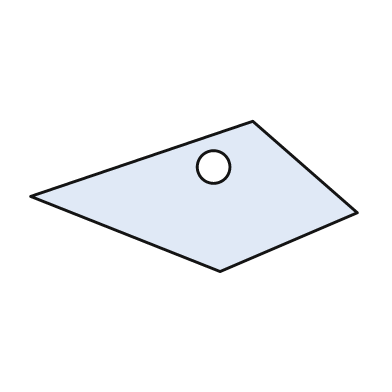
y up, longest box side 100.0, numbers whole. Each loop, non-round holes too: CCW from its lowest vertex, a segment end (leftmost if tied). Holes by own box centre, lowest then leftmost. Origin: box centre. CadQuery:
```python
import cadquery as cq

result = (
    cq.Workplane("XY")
    .moveTo(8.0, -23.0)
    .lineTo(50.0, -5.0)
    .lineTo(18.0, 23.0)
    .lineTo(-50.0, 0.0)
    .close()
    .moveTo(6.0, 9.0)
    .circle(5.0)
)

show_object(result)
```